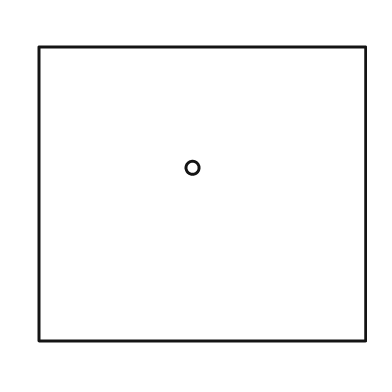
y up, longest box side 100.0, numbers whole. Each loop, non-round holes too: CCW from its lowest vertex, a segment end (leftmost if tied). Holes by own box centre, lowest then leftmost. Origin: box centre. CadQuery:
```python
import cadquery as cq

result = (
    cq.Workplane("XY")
    .moveTo(-50.0, -45.0)
    .lineTo(50.0, -45.0)
    .lineTo(50.0, 45.0)
    .lineTo(-50.0, 45.0)
    .close()
    .moveTo(-3.0, 8.0)
    .circle(2.0)
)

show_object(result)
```